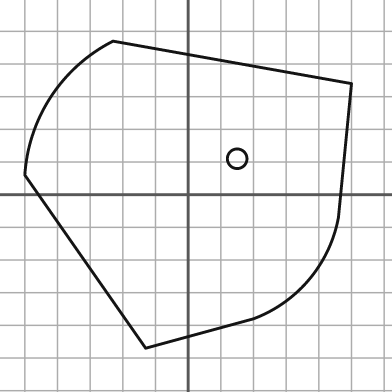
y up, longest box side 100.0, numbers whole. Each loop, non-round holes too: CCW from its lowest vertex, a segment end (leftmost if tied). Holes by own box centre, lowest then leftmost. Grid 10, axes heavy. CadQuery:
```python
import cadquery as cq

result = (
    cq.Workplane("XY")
    .moveTo(-13.0, -47.0)
    .lineTo(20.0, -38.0)
    .threePointArc((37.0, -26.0), (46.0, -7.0))
    .lineTo(50.0, 34.0)
    .lineTo(-23.0, 47.0)
    .threePointArc((-42.0, 30.0), (-50.0, 6.0))
    .close()
    .moveTo(15.0, 11.0)
    .circle(3.0)
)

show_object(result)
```